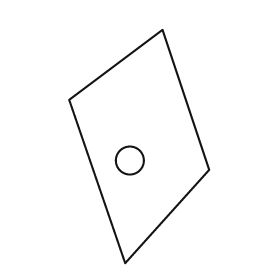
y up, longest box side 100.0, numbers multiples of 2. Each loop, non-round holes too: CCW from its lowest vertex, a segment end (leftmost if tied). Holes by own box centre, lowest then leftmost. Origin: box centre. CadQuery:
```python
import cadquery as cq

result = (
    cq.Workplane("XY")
    .moveTo(-6.0, -50.0)
    .lineTo(30.0, -10.0)
    .lineTo(10.0, 50.0)
    .lineTo(-30.0, 20.0)
    .close()
    .moveTo(-4.0, -6.0)
    .circle(6.0)
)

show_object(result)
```